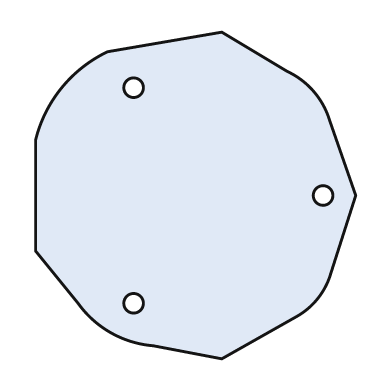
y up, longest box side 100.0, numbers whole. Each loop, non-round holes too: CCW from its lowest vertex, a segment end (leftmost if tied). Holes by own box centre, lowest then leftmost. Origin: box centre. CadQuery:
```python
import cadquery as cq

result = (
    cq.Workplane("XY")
    .moveTo(8.0, -50.0)
    .lineTo(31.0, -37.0)
    .threePointArc((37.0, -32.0), (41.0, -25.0))
    .lineTo(49.0, 0.0)
    .lineTo(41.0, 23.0)
    .threePointArc((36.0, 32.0), (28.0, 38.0))
    .lineTo(8.0, 50.0)
    .lineTo(-27.0, 44.0)
    .threePointArc((-41.0, 33.0), (-49.0, 17.0))
    .lineTo(-49.0, -17.0)
    .lineTo(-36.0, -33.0)
    .threePointArc((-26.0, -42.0), (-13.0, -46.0))
    .close()
    .moveTo(-19.0, -33.0)
    .circle(3.0)
    .moveTo(39.0, 0.0)
    .circle(3.0)
    .moveTo(-19.0, 33.0)
    .circle(3.0)
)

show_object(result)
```